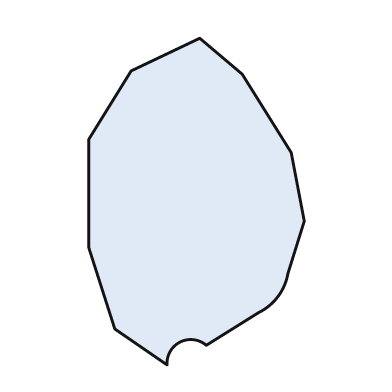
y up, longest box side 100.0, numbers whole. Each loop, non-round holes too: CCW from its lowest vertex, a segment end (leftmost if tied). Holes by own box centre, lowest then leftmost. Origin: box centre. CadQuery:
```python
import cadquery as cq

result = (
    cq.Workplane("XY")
    .moveTo(-9.0, -50.0)
    .threePointArc((-5.0, -43.0), (3.0, -44.0))
    .lineTo(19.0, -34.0)
    .threePointArc((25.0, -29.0), (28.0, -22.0))
    .lineTo(33.0, -6.0)
    .lineTo(29.0, 15.0)
    .lineTo(14.0, 39.0)
    .lineTo(1.0, 50.0)
    .lineTo(-20.0, 40.0)
    .lineTo(-33.0, 19.0)
    .lineTo(-33.0, -14.0)
    .lineTo(-25.0, -39.0)
    .close()
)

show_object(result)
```